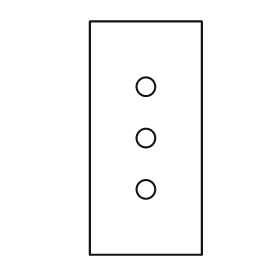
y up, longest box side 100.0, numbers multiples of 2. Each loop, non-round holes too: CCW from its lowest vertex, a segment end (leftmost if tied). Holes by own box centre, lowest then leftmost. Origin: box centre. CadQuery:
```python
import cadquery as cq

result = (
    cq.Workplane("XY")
    .moveTo(-24.0, -50.0)
    .lineTo(24.0, -50.0)
    .lineTo(24.0, 50.0)
    .lineTo(-24.0, 50.0)
    .close()
    .moveTo(0.0, -22.0)
    .circle(4.0)
    .moveTo(0.0, 0.0)
    .circle(4.0)
    .moveTo(0.0, 22.0)
    .circle(4.0)
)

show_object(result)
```